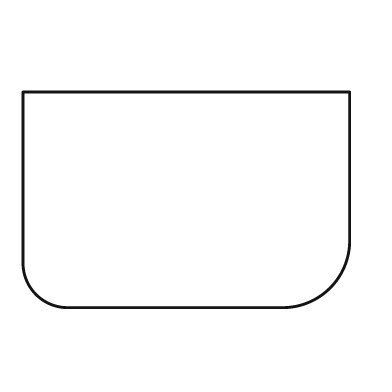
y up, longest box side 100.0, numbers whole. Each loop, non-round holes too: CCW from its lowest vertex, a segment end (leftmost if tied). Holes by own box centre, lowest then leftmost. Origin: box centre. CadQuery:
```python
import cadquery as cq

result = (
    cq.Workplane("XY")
    .moveTo(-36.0, -33.0)
    .lineTo(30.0, -33.0)
    .threePointArc((44.0, -27.0), (50.0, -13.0))
    .lineTo(50.0, 33.0)
    .lineTo(-50.0, 33.0)
    .lineTo(-50.0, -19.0)
    .threePointArc((-46.0, -29.0), (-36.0, -33.0))
    .close()
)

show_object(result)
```